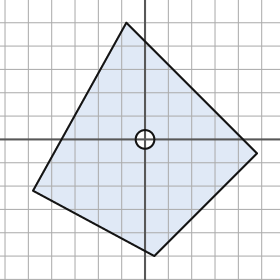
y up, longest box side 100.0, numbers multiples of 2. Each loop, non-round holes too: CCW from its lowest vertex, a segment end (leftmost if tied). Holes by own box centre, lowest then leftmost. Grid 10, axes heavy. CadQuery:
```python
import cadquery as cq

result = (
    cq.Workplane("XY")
    .moveTo(4.0, -50.0)
    .lineTo(48.0, -6.0)
    .lineTo(-8.0, 50.0)
    .lineTo(-48.0, -22.0)
    .close()
    .moveTo(0.0, 0.0)
    .circle(4.0)
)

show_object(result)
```